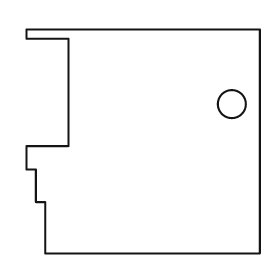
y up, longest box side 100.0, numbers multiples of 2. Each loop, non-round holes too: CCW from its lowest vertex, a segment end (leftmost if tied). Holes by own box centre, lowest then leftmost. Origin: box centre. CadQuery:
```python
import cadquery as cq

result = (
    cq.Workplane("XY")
    .moveTo(-42.0, -48.0)
    .lineTo(50.0, -48.0)
    .lineTo(50.0, 48.0)
    .lineTo(-50.0, 48.0)
    .lineTo(-50.0, 44.0)
    .lineTo(-32.0, 44.0)
    .lineTo(-32.0, -2.0)
    .lineTo(-50.0, -2.0)
    .lineTo(-50.0, -12.0)
    .lineTo(-46.0, -12.0)
    .lineTo(-46.0, -26.0)
    .lineTo(-42.0, -26.0)
    .close()
    .moveTo(38.0, 16.0)
    .circle(6.0)
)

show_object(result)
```